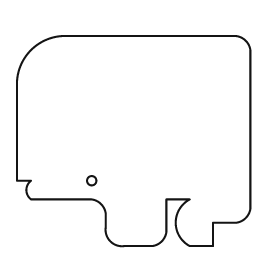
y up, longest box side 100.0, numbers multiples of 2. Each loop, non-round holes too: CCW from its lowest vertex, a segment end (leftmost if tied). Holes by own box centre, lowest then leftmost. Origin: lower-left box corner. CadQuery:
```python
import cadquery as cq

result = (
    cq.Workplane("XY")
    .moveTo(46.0, 0.0)
    .lineTo(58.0, 0.0)
    .threePointArc((62.0, 2.0), (64.0, 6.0))
    .lineTo(64.0, 20.0)
    .lineTo(74.0, 20.0)
    .threePointArc((68.0, 10.0), (74.0, 0.0))
    .lineTo(84.0, 0.0)
    .lineTo(84.0, 10.0)
    .lineTo(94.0, 10.0)
    .threePointArc((98.0, 12.0), (100.0, 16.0))
    .lineTo(100.0, 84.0)
    .threePointArc((98.0, 88.0), (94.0, 90.0))
    .lineTo(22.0, 90.0)
    .threePointArc((6.0, 84.0), (0.0, 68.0))
    .lineTo(0.0, 28.0)
    .lineTo(6.0, 28.0)
    .threePointArc((4.0, 24.0), (6.0, 20.0))
    .lineTo(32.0, 20.0)
    .threePointArc((36.0, 18.0), (38.0, 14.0))
    .lineTo(38.0, 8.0)
    .threePointArc((40.0, 2.0), (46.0, 0.0))
    .close()
    .moveTo(32.0, 28.0)
    .circle(2.0)
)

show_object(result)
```